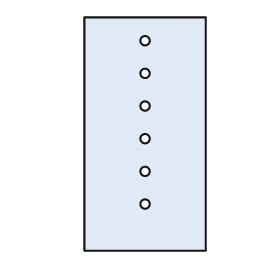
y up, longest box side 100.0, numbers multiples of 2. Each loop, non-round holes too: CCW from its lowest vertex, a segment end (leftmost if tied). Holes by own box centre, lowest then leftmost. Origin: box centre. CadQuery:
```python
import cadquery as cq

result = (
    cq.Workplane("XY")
    .moveTo(-26.0, -50.0)
    .lineTo(26.0, -50.0)
    .lineTo(26.0, 50.0)
    .lineTo(-26.0, 50.0)
    .close()
    .moveTo(0.0, -30.0)
    .circle(2.0)
    .moveTo(0.0, -16.0)
    .circle(2.0)
    .moveTo(0.0, -2.0)
    .circle(2.0)
    .moveTo(0.0, 12.0)
    .circle(2.0)
    .moveTo(0.0, 26.0)
    .circle(2.0)
    .moveTo(0.0, 40.0)
    .circle(2.0)
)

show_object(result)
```